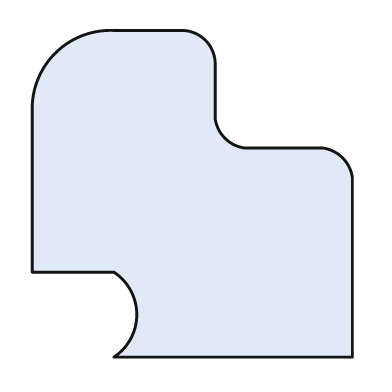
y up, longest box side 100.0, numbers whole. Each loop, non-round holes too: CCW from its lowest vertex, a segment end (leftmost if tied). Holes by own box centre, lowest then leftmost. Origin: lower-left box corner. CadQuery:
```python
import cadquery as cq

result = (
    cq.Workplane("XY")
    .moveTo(25.0, 0.0)
    .lineTo(98.0, 0.0)
    .lineTo(98.0, 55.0)
    .threePointArc((95.0, 61.0), (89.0, 64.0))
    .lineTo(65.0, 64.0)
    .threePointArc((59.0, 67.0), (56.0, 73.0))
    .lineTo(56.0, 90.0)
    .threePointArc((53.0, 97.0), (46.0, 100.0))
    .lineTo(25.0, 100.0)
    .threePointArc((7.0, 93.0), (0.0, 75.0))
    .lineTo(0.0, 26.0)
    .lineTo(25.0, 26.0)
    .threePointArc((32.0, 13.0), (25.0, 0.0))
    .close()
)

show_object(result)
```